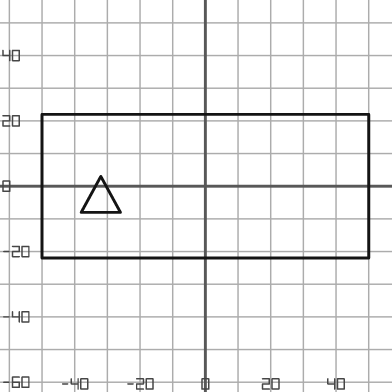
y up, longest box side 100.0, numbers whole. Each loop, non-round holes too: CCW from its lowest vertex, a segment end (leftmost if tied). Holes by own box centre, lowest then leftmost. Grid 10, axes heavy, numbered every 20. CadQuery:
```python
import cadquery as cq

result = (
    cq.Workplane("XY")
    .moveTo(-50.0, -22.0)
    .lineTo(50.0, -22.0)
    .lineTo(50.0, 22.0)
    .lineTo(-50.0, 22.0)
    .close()
    .moveTo(-38.0, -8.0)
    .lineTo(-26.0, -8.0)
    .lineTo(-32.0, 3.0)
    .close()
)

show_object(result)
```